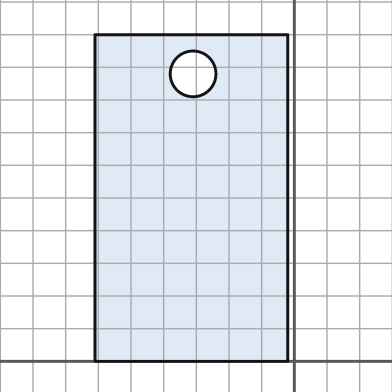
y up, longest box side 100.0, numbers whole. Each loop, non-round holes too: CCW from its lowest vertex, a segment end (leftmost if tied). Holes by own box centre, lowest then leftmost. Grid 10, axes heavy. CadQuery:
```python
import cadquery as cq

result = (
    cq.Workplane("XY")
    .moveTo(-61.0, 0.0)
    .lineTo(-2.0, 0.0)
    .lineTo(-2.0, 100.0)
    .lineTo(-61.0, 100.0)
    .close()
    .moveTo(-31.0, 88.0)
    .circle(7.0)
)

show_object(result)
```